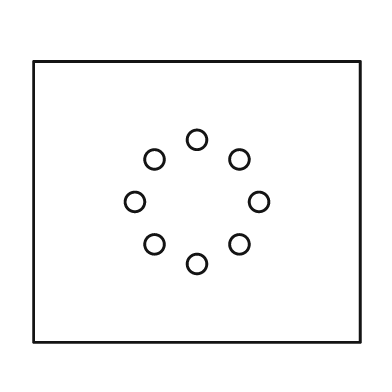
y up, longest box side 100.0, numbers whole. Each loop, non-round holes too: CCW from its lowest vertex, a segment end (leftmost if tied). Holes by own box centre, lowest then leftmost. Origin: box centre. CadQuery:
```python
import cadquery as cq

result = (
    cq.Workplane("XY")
    .moveTo(-50.0, -43.0)
    .lineTo(50.0, -43.0)
    .lineTo(50.0, 43.0)
    .lineTo(-50.0, 43.0)
    .close()
    .moveTo(0.0, -19.0)
    .circle(3.0)
    .moveTo(-13.0, -13.0)
    .circle(3.0)
    .moveTo(13.0, -13.0)
    .circle(3.0)
    .moveTo(-19.0, 0.0)
    .circle(3.0)
    .moveTo(19.0, 0.0)
    .circle(3.0)
    .moveTo(-13.0, 13.0)
    .circle(3.0)
    .moveTo(13.0, 13.0)
    .circle(3.0)
    .moveTo(0.0, 19.0)
    .circle(3.0)
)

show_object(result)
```